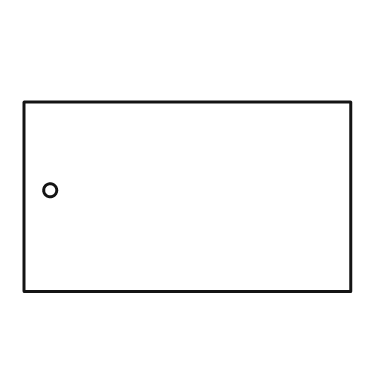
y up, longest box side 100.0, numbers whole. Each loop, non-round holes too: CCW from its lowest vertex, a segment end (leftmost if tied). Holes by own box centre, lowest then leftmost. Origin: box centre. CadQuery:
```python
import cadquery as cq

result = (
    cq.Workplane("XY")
    .moveTo(-50.0, -29.0)
    .lineTo(50.0, -29.0)
    .lineTo(50.0, 29.0)
    .lineTo(-50.0, 29.0)
    .close()
    .moveTo(-42.0, 2.0)
    .circle(2.0)
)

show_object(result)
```